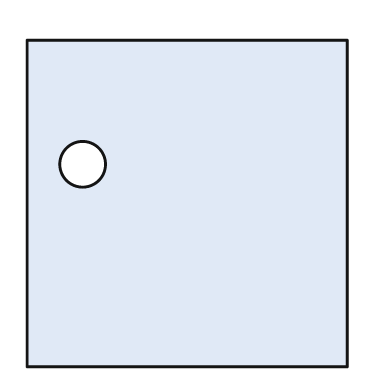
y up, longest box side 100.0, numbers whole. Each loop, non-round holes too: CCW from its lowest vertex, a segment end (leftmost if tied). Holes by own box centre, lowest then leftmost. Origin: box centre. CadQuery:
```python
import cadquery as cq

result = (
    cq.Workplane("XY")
    .moveTo(-49.0, -50.0)
    .lineTo(49.0, -50.0)
    .lineTo(49.0, 50.0)
    .lineTo(-49.0, 50.0)
    .close()
    .moveTo(-32.0, 12.0)
    .circle(7.0)
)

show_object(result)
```